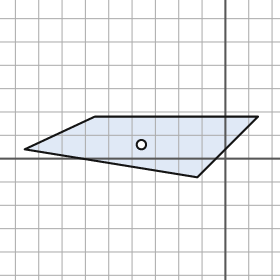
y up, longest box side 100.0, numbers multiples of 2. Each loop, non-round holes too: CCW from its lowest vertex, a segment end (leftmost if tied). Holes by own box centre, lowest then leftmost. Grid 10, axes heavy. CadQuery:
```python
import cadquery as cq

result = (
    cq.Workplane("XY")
    .moveTo(-12.0, -8.0)
    .lineTo(14.0, 18.0)
    .lineTo(-56.0, 18.0)
    .lineTo(-86.0, 4.0)
    .close()
    .moveTo(-36.0, 6.0)
    .circle(2.0)
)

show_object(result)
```